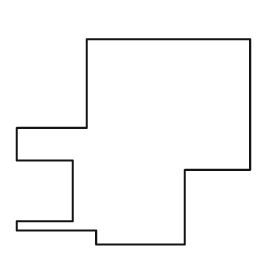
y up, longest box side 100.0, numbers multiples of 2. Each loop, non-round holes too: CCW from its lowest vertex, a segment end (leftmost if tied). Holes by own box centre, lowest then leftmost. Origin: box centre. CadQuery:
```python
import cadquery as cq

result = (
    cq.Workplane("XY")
    .moveTo(-16.0, -44.0)
    .lineTo(22.0, -44.0)
    .lineTo(22.0, -12.0)
    .lineTo(50.0, -12.0)
    .lineTo(50.0, 44.0)
    .lineTo(-20.0, 44.0)
    .lineTo(-20.0, 6.0)
    .lineTo(-50.0, 6.0)
    .lineTo(-50.0, -8.0)
    .lineTo(-26.0, -8.0)
    .lineTo(-26.0, -34.0)
    .lineTo(-50.0, -34.0)
    .lineTo(-50.0, -38.0)
    .lineTo(-16.0, -38.0)
    .close()
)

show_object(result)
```